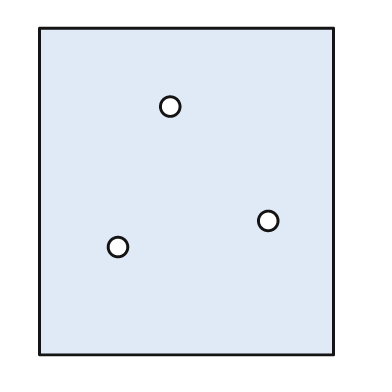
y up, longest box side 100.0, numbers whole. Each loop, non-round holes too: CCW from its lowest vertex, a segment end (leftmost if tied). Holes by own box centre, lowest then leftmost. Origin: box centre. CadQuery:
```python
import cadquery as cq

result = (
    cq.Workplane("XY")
    .moveTo(-45.0, -50.0)
    .lineTo(45.0, -50.0)
    .lineTo(45.0, 50.0)
    .lineTo(-45.0, 50.0)
    .close()
    .moveTo(-21.0, -17.0)
    .circle(3.0)
    .moveTo(25.0, -9.0)
    .circle(3.0)
    .moveTo(-5.0, 26.0)
    .circle(3.0)
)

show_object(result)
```